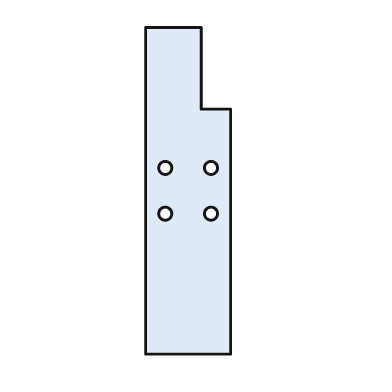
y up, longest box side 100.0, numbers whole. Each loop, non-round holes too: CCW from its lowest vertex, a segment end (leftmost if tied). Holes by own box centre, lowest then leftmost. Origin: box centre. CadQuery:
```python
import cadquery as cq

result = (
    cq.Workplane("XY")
    .moveTo(-13.0, -50.0)
    .lineTo(13.0, -50.0)
    .lineTo(13.0, 25.0)
    .lineTo(4.0, 25.0)
    .lineTo(4.0, 50.0)
    .lineTo(-13.0, 50.0)
    .close()
    .moveTo(-7.0, -7.0)
    .circle(2.0)
    .moveTo(7.0, -7.0)
    .circle(2.0)
    .moveTo(-7.0, 7.0)
    .circle(2.0)
    .moveTo(7.0, 7.0)
    .circle(2.0)
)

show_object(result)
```